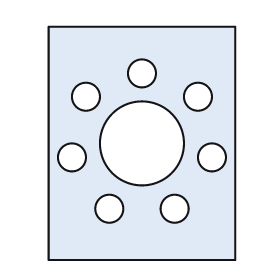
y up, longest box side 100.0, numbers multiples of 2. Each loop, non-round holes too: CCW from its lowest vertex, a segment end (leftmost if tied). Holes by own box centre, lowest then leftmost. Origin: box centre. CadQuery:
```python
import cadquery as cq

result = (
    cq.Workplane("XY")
    .moveTo(-40.0, -50.0)
    .lineTo(40.0, -50.0)
    .lineTo(40.0, 50.0)
    .lineTo(-40.0, 50.0)
    .close()
    .moveTo(-14.0, -28.0)
    .circle(6.0)
    .moveTo(14.0, -28.0)
    .circle(6.0)
    .moveTo(-30.0, -6.0)
    .circle(6.0)
    .moveTo(30.0, -6.0)
    .circle(6.0)
    .moveTo(0.0, 0.0)
    .circle(18.0)
    .moveTo(-24.0, 20.0)
    .circle(6.0)
    .moveTo(24.0, 20.0)
    .circle(6.0)
    .moveTo(0.0, 30.0)
    .circle(6.0)
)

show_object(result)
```